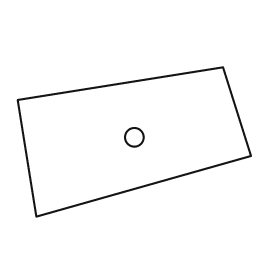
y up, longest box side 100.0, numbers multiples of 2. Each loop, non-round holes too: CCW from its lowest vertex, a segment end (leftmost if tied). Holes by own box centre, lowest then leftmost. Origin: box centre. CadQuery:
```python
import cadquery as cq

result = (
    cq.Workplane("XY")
    .moveTo(-42.0, -32.0)
    .lineTo(50.0, -6.0)
    .lineTo(38.0, 32.0)
    .lineTo(-50.0, 18.0)
    .close()
    .moveTo(0.0, 2.0)
    .circle(4.0)
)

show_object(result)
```